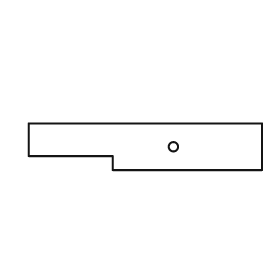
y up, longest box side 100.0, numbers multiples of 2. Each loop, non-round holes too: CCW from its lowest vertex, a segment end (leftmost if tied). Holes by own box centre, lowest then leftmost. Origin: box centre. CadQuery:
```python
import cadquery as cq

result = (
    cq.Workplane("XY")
    .moveTo(-14.0, -10.0)
    .lineTo(50.0, -10.0)
    .lineTo(50.0, 10.0)
    .lineTo(-50.0, 10.0)
    .lineTo(-50.0, -4.0)
    .lineTo(-14.0, -4.0)
    .close()
    .moveTo(12.0, 0.0)
    .circle(2.0)
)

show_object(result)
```